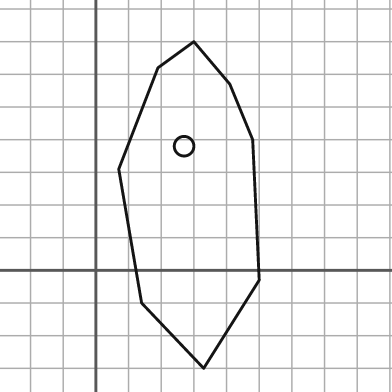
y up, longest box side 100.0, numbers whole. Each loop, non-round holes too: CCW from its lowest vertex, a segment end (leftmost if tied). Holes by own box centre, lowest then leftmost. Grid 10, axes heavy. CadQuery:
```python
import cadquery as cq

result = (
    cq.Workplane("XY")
    .moveTo(33.0, -30.0)
    .lineTo(50.0, -3.0)
    .lineTo(48.0, 40.0)
    .lineTo(41.0, 57.0)
    .lineTo(30.0, 70.0)
    .lineTo(19.0, 62.0)
    .lineTo(7.0, 31.0)
    .lineTo(14.0, -10.0)
    .close()
    .moveTo(27.0, 38.0)
    .circle(3.0)
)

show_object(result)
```